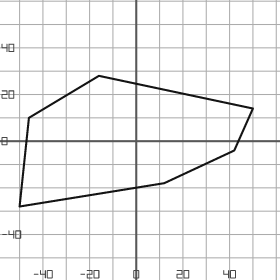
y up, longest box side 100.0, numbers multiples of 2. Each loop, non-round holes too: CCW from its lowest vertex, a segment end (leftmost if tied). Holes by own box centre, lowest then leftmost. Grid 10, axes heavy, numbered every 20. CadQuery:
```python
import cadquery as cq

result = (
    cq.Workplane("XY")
    .moveTo(-50.0, -28.0)
    .lineTo(12.0, -18.0)
    .lineTo(42.0, -4.0)
    .lineTo(50.0, 14.0)
    .lineTo(-16.0, 28.0)
    .lineTo(-46.0, 10.0)
    .close()
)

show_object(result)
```